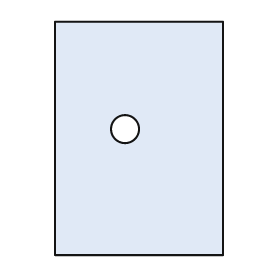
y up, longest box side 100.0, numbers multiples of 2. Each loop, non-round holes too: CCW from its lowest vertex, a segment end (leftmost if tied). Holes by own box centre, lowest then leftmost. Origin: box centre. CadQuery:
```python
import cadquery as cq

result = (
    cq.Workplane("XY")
    .moveTo(-36.0, -50.0)
    .lineTo(36.0, -50.0)
    .lineTo(36.0, 50.0)
    .lineTo(-36.0, 50.0)
    .close()
    .moveTo(-6.0, 4.0)
    .circle(6.0)
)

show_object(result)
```